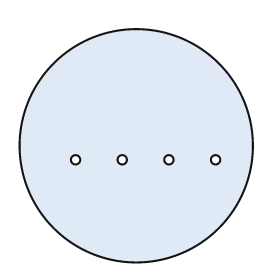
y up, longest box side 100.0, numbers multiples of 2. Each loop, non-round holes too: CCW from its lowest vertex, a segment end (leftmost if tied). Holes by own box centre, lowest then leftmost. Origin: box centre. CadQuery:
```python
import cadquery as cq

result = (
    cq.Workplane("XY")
    .moveTo(0.0, 0.0)
    .circle(50.0)
    .moveTo(-26.0, -6.0)
    .circle(2.0)
    .moveTo(-6.0, -6.0)
    .circle(2.0)
    .moveTo(14.0, -6.0)
    .circle(2.0)
    .moveTo(34.0, -6.0)
    .circle(2.0)
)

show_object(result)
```